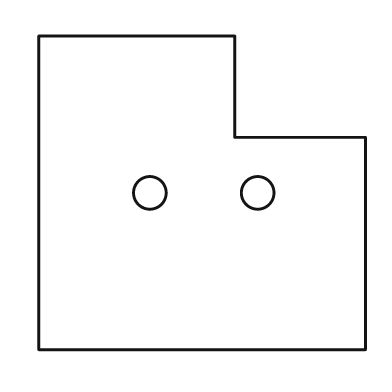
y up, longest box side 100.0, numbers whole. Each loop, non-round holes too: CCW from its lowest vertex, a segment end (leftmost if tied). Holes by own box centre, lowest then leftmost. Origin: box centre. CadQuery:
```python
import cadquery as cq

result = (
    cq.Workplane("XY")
    .moveTo(-50.0, -48.0)
    .lineTo(50.0, -48.0)
    .lineTo(50.0, 17.0)
    .lineTo(10.0, 17.0)
    .lineTo(10.0, 48.0)
    .lineTo(-50.0, 48.0)
    .close()
    .moveTo(-16.0, 0.0)
    .circle(5.0)
    .moveTo(17.0, 0.0)
    .circle(5.0)
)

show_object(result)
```